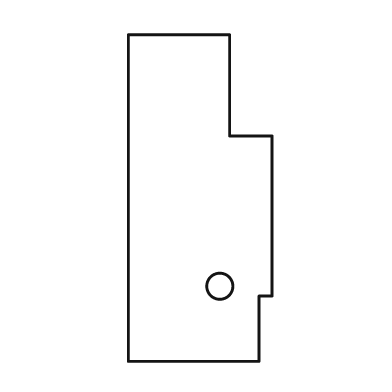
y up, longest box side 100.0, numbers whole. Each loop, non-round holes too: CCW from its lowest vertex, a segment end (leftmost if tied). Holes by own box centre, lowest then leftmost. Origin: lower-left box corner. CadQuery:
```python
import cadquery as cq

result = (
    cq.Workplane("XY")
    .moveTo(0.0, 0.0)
    .lineTo(40.0, 0.0)
    .lineTo(40.0, 20.0)
    .lineTo(44.0, 20.0)
    .lineTo(44.0, 69.0)
    .lineTo(31.0, 69.0)
    .lineTo(31.0, 100.0)
    .lineTo(0.0, 100.0)
    .close()
    .moveTo(28.0, 23.0)
    .circle(4.0)
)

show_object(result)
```